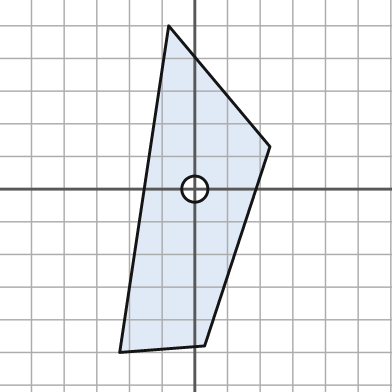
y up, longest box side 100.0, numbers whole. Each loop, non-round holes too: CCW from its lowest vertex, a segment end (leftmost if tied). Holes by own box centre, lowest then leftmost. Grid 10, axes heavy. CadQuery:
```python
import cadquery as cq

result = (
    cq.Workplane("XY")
    .moveTo(-23.0, -50.0)
    .lineTo(3.0, -48.0)
    .lineTo(23.0, 13.0)
    .lineTo(-8.0, 50.0)
    .close()
    .moveTo(0.0, 0.0)
    .circle(4.0)
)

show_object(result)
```